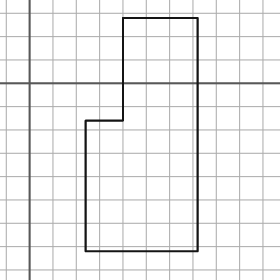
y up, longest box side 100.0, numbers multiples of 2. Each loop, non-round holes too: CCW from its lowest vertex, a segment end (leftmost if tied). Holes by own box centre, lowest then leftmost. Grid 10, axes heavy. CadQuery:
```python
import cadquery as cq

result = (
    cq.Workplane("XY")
    .moveTo(24.0, -72.0)
    .lineTo(72.0, -72.0)
    .lineTo(72.0, 28.0)
    .lineTo(40.0, 28.0)
    .lineTo(40.0, -16.0)
    .lineTo(24.0, -16.0)
    .close()
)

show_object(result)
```